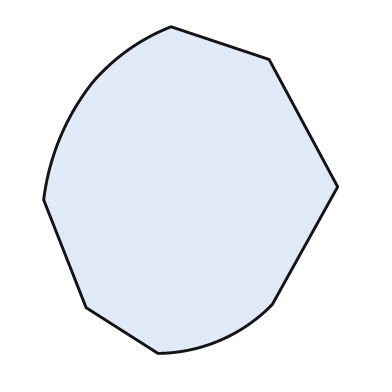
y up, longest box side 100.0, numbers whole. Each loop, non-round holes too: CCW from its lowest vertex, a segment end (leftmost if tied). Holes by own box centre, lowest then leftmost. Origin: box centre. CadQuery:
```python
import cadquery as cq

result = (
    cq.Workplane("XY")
    .moveTo(-10.0, -50.0)
    .threePointArc((9.0, -46.0), (25.0, -35.0))
    .lineTo(45.0, 1.0)
    .lineTo(24.0, 40.0)
    .lineTo(-6.0, 50.0)
    .threePointArc((-19.0, 43.0), (-30.0, 33.0))
    .threePointArc((-40.0, 16.0), (-45.0, -3.0))
    .lineTo(-32.0, -36.0)
    .close()
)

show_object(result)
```